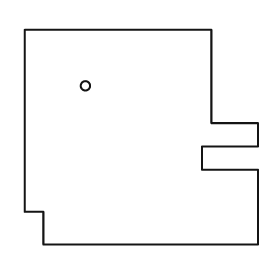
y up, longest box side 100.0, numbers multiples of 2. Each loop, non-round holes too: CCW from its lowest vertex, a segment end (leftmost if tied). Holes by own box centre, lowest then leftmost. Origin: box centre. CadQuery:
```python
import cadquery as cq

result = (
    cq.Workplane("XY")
    .moveTo(-42.0, -46.0)
    .lineTo(50.0, -46.0)
    .lineTo(50.0, -14.0)
    .lineTo(26.0, -14.0)
    .lineTo(26.0, -4.0)
    .lineTo(50.0, -4.0)
    .lineTo(50.0, 6.0)
    .lineTo(30.0, 6.0)
    .lineTo(30.0, 46.0)
    .lineTo(-50.0, 46.0)
    .lineTo(-50.0, -32.0)
    .lineTo(-42.0, -32.0)
    .close()
    .moveTo(-24.0, 22.0)
    .circle(2.0)
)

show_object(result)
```